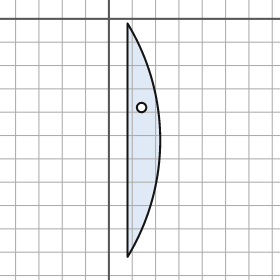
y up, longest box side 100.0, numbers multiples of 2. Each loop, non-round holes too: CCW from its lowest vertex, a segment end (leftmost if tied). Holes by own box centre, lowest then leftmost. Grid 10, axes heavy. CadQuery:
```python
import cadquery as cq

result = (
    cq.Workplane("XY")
    .moveTo(8.0, -102.0)
    .threePointArc((22.0, -52.0), (8.0, -2.0))
    .close()
    .moveTo(14.0, -38.0)
    .circle(2.0)
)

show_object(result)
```